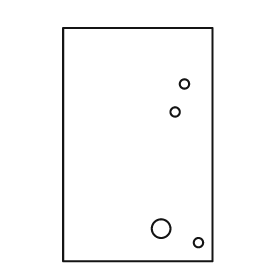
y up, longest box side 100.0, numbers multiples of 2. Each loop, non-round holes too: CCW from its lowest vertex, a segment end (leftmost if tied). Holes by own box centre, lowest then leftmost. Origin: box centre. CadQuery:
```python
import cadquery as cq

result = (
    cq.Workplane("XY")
    .moveTo(-32.0, -50.0)
    .lineTo(32.0, -50.0)
    .lineTo(32.0, 50.0)
    .lineTo(-32.0, 50.0)
    .close()
    .moveTo(26.0, -42.0)
    .circle(2.0)
    .moveTo(10.0, -36.0)
    .circle(4.0)
    .moveTo(16.0, 14.0)
    .circle(2.0)
    .moveTo(20.0, 26.0)
    .circle(2.0)
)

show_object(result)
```